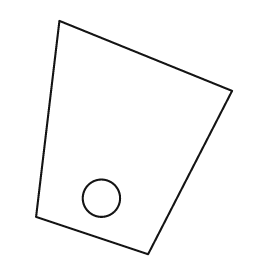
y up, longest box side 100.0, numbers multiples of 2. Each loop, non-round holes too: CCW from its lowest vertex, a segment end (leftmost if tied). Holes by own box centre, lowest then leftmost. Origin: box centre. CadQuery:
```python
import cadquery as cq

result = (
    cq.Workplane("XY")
    .moveTo(6.0, -50.0)
    .lineTo(42.0, 20.0)
    .lineTo(-32.0, 50.0)
    .lineTo(-42.0, -34.0)
    .close()
    .moveTo(-14.0, -26.0)
    .circle(8.0)
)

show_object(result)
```